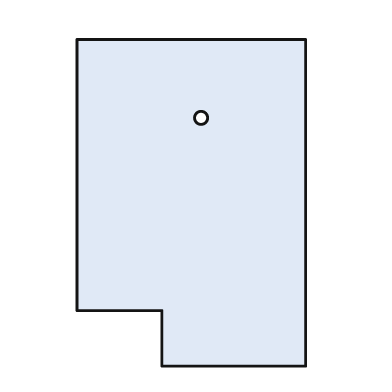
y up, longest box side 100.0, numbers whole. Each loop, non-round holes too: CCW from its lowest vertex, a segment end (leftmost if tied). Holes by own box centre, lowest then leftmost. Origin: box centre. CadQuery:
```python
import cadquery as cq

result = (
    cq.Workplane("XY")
    .moveTo(-9.0, -50.0)
    .lineTo(35.0, -50.0)
    .lineTo(35.0, 50.0)
    .lineTo(-35.0, 50.0)
    .lineTo(-35.0, -33.0)
    .lineTo(-9.0, -33.0)
    .close()
    .moveTo(3.0, 26.0)
    .circle(2.0)
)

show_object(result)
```